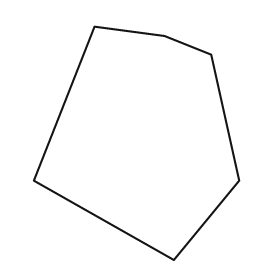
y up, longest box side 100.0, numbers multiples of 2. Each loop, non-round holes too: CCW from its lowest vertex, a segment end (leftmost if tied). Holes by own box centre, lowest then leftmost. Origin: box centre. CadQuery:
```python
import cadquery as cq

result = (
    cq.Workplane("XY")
    .moveTo(16.0, -50.0)
    .lineTo(44.0, -16.0)
    .lineTo(32.0, 38.0)
    .lineTo(12.0, 46.0)
    .lineTo(-18.0, 50.0)
    .lineTo(-44.0, -16.0)
    .close()
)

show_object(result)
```